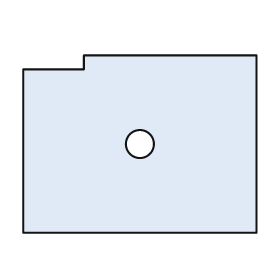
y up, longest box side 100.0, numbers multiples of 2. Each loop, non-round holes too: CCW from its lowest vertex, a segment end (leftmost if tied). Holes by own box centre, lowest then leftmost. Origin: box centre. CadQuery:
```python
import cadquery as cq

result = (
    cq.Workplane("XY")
    .moveTo(-50.0, -38.0)
    .lineTo(50.0, -38.0)
    .lineTo(50.0, 38.0)
    .lineTo(-24.0, 38.0)
    .lineTo(-24.0, 32.0)
    .lineTo(-50.0, 32.0)
    .close()
    .moveTo(0.0, 0.0)
    .circle(6.0)
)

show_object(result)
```